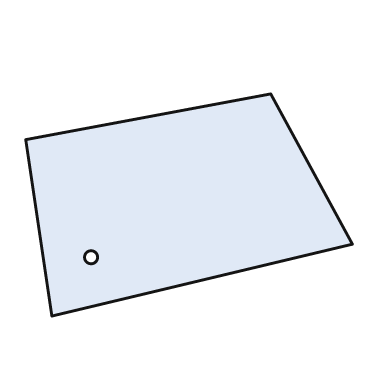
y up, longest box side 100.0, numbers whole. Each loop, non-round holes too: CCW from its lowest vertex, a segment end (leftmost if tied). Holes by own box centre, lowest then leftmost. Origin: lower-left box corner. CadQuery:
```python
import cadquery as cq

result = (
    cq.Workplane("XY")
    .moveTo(8.0, 0.0)
    .lineTo(100.0, 22.0)
    .lineTo(75.0, 68.0)
    .lineTo(0.0, 54.0)
    .close()
    .moveTo(20.0, 18.0)
    .circle(2.0)
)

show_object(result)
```